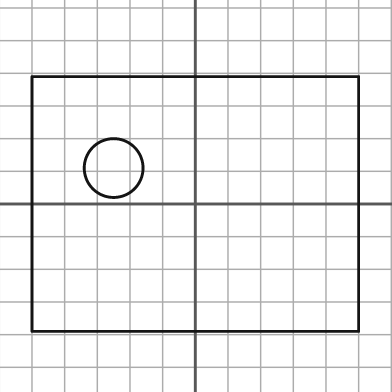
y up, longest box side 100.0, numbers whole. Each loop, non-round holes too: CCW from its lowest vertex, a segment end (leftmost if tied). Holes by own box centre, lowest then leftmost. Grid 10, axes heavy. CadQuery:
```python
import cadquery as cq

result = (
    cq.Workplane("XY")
    .moveTo(-50.0, -39.0)
    .lineTo(50.0, -39.0)
    .lineTo(50.0, 39.0)
    .lineTo(-50.0, 39.0)
    .close()
    .moveTo(-25.0, 11.0)
    .circle(9.0)
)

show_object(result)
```